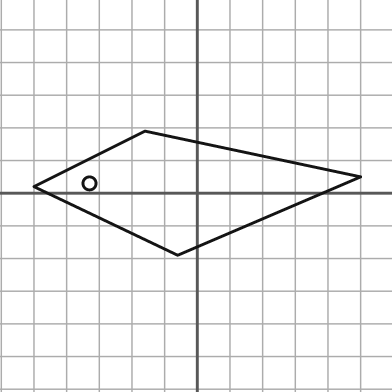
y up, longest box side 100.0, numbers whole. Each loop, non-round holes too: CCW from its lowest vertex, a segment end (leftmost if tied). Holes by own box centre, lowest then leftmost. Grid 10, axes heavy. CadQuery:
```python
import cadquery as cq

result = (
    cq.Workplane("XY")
    .moveTo(-6.0, -19.0)
    .lineTo(50.0, 5.0)
    .lineTo(-16.0, 19.0)
    .lineTo(-50.0, 2.0)
    .close()
    .moveTo(-33.0, 3.0)
    .circle(2.0)
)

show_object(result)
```